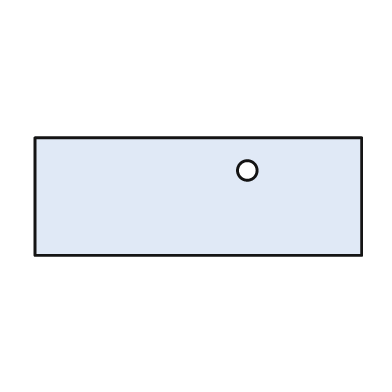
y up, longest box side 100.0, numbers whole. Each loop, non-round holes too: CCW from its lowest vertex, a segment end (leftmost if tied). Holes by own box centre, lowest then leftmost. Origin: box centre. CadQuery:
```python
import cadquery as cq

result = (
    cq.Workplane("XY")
    .moveTo(-50.0, -18.0)
    .lineTo(50.0, -18.0)
    .lineTo(50.0, 18.0)
    .lineTo(-50.0, 18.0)
    .close()
    .moveTo(15.0, 8.0)
    .circle(3.0)
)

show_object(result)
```